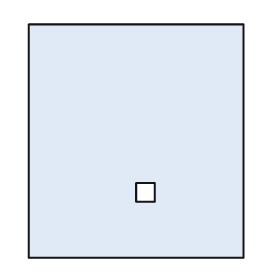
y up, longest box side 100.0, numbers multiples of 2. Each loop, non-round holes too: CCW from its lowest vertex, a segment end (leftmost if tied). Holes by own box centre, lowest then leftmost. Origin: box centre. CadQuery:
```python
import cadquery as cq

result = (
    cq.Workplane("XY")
    .moveTo(-46.0, -50.0)
    .lineTo(46.0, -50.0)
    .lineTo(46.0, 50.0)
    .lineTo(-46.0, 50.0)
    .close()
    .moveTo(0.0, -26.0)
    .lineTo(8.0, -26.0)
    .lineTo(8.0, -18.0)
    .lineTo(0.0, -18.0)
    .close()
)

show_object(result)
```